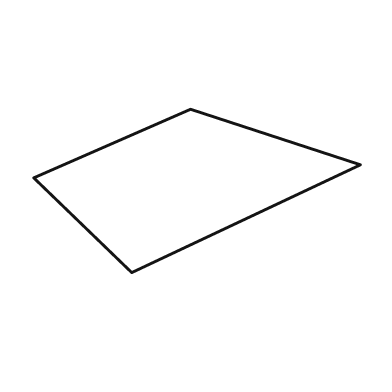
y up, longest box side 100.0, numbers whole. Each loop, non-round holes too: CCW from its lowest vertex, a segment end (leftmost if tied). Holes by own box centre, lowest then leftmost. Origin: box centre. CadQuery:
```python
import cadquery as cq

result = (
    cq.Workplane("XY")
    .moveTo(-20.0, -25.0)
    .lineTo(50.0, 8.0)
    .lineTo(-2.0, 25.0)
    .lineTo(-50.0, 4.0)
    .close()
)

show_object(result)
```